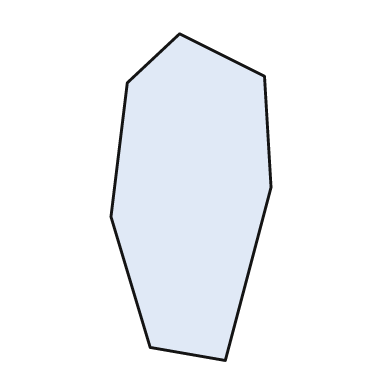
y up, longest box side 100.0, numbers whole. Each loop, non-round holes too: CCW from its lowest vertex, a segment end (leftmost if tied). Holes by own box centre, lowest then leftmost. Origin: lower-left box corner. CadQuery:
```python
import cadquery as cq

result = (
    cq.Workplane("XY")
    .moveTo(35.0, 0.0)
    .lineTo(49.0, 53.0)
    .lineTo(47.0, 87.0)
    .lineTo(21.0, 100.0)
    .lineTo(5.0, 85.0)
    .lineTo(0.0, 44.0)
    .lineTo(12.0, 4.0)
    .close()
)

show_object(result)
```